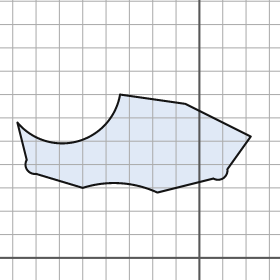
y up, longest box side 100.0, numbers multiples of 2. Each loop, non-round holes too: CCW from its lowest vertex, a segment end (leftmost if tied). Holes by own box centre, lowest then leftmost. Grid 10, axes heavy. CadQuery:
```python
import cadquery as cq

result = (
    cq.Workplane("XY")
    .moveTo(-18.0, 28.0)
    .lineTo(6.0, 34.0)
    .threePointArc((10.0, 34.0), (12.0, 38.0))
    .lineTo(22.0, 52.0)
    .lineTo(-6.0, 66.0)
    .lineTo(-34.0, 70.0)
    .threePointArc((-52.0, 50.0), (-78.0, 58.0))
    .lineTo(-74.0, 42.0)
    .threePointArc((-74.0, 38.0), (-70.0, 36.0))
    .lineTo(-50.0, 30.0)
    .threePointArc((-34.0, 32.0), (-18.0, 28.0))
    .close()
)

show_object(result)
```